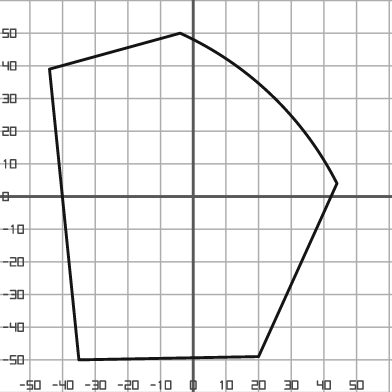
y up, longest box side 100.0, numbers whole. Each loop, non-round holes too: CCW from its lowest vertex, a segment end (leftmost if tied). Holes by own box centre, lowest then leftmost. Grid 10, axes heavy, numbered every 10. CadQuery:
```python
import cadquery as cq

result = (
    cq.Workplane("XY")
    .moveTo(-35.0, -50.0)
    .lineTo(20.0, -49.0)
    .lineTo(44.0, 4.0)
    .threePointArc((24.0, 31.0), (-4.0, 50.0))
    .lineTo(-44.0, 39.0)
    .close()
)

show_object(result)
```